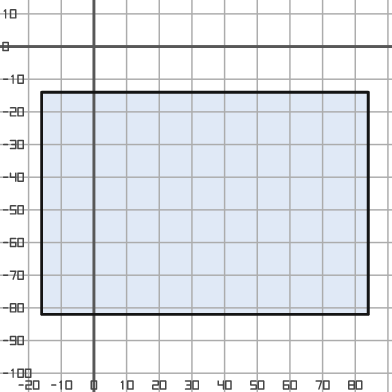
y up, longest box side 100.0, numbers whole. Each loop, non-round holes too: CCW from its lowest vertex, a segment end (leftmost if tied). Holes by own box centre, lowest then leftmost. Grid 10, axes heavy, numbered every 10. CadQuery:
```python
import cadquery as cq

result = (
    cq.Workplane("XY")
    .moveTo(-16.0, -82.0)
    .lineTo(84.0, -82.0)
    .lineTo(84.0, -14.0)
    .lineTo(-16.0, -14.0)
    .close()
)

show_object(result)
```